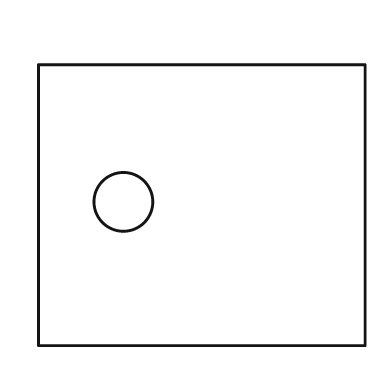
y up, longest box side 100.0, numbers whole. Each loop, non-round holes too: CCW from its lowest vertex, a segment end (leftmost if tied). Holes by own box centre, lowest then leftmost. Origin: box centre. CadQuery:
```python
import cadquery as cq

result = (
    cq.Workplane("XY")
    .moveTo(-50.0, -43.0)
    .lineTo(50.0, -43.0)
    .lineTo(50.0, 43.0)
    .lineTo(-50.0, 43.0)
    .close()
    .moveTo(-24.0, 1.0)
    .circle(9.0)
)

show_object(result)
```